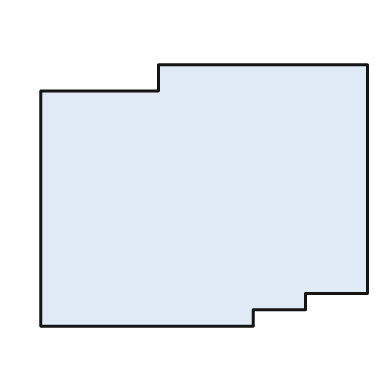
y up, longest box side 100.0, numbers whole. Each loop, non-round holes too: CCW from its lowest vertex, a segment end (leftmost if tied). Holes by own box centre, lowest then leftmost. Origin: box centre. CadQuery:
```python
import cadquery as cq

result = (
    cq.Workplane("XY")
    .moveTo(-50.0, -40.0)
    .lineTo(15.0, -40.0)
    .lineTo(15.0, -35.0)
    .lineTo(31.0, -35.0)
    .lineTo(31.0, -30.0)
    .lineTo(50.0, -30.0)
    .lineTo(50.0, 40.0)
    .lineTo(-14.0, 40.0)
    .lineTo(-14.0, 32.0)
    .lineTo(-50.0, 32.0)
    .close()
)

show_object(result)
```